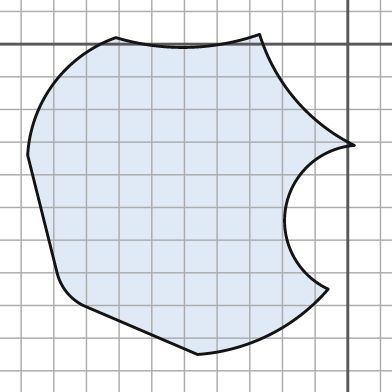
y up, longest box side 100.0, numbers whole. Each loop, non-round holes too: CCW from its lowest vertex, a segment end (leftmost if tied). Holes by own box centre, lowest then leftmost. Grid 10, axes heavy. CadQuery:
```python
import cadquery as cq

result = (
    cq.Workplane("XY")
    .moveTo(-46.0, -95.0)
    .threePointArc((-24.0, -89.0), (-6.0, -75.0))
    .threePointArc((-19.0, -50.0), (2.0, -31.0))
    .threePointArc((-16.0, -17.0), (-27.0, 3.0))
    .threePointArc((-49.0, -1.0), (-71.0, 2.0))
    .threePointArc((-90.0, -12.0), (-98.0, -34.0))
    .lineTo(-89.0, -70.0)
    .threePointArc((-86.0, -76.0), (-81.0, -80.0))
    .close()
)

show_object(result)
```